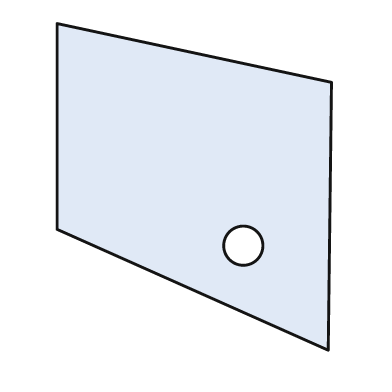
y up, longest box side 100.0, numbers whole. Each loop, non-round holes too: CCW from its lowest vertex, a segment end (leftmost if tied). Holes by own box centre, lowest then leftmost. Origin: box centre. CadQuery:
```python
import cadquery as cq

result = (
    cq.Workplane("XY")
    .moveTo(41.0, -50.0)
    .lineTo(42.0, 32.0)
    .lineTo(-42.0, 50.0)
    .lineTo(-42.0, -13.0)
    .close()
    .moveTo(15.0, -18.0)
    .circle(6.0)
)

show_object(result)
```